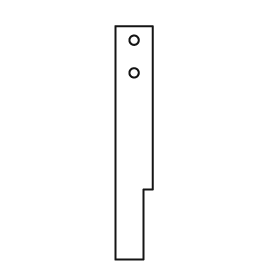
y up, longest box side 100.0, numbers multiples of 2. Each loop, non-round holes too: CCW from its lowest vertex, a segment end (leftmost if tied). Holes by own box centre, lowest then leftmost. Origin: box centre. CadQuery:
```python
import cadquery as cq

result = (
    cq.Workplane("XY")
    .moveTo(-8.0, -50.0)
    .lineTo(4.0, -50.0)
    .lineTo(4.0, -20.0)
    .lineTo(8.0, -20.0)
    .lineTo(8.0, 50.0)
    .lineTo(-8.0, 50.0)
    .close()
    .moveTo(0.0, 30.0)
    .circle(2.0)
    .moveTo(0.0, 44.0)
    .circle(2.0)
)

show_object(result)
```